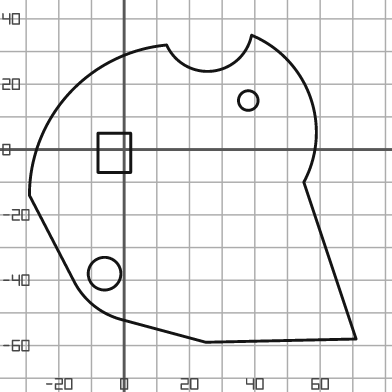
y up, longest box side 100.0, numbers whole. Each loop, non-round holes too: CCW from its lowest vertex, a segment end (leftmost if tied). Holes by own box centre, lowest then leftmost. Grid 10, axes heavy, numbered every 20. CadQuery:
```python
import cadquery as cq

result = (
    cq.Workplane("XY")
    .moveTo(25.0, -59.0)
    .lineTo(71.0, -58.0)
    .lineTo(55.0, -10.0)
    .threePointArc((57.0, 16.0), (39.0, 35.0))
    .threePointArc((27.0, 24.0), (13.0, 32.0))
    .threePointArc((-17.0, 17.0), (-29.0, -14.0))
    .lineTo(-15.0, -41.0)
    .threePointArc((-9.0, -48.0), (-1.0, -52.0))
    .close()
    .moveTo(-6.0, -38.0)
    .circle(5.0)
    .moveTo(-8.0, -7.0)
    .lineTo(2.0, -7.0)
    .lineTo(2.0, 5.0)
    .lineTo(-8.0, 5.0)
    .close()
    .moveTo(38.0, 15.0)
    .circle(3.0)
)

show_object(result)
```